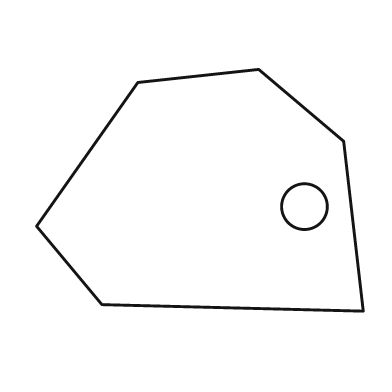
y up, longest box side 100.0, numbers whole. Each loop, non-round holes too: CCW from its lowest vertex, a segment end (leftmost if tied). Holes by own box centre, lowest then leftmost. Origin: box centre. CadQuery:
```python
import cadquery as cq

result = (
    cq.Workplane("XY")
    .moveTo(50.0, -37.0)
    .lineTo(44.0, 15.0)
    .lineTo(18.0, 37.0)
    .lineTo(-19.0, 33.0)
    .lineTo(-50.0, -11.0)
    .lineTo(-30.0, -35.0)
    .close()
    .moveTo(32.0, -5.0)
    .circle(7.0)
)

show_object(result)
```